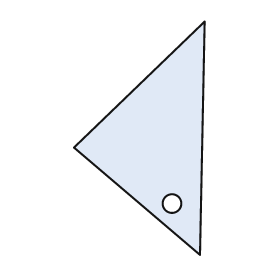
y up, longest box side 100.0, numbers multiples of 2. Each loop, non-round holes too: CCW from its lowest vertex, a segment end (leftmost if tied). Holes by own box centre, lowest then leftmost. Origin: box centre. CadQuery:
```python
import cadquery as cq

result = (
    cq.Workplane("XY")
    .moveTo(26.0, -50.0)
    .lineTo(28.0, 50.0)
    .lineTo(-28.0, -4.0)
    .close()
    .moveTo(14.0, -28.0)
    .circle(4.0)
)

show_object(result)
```